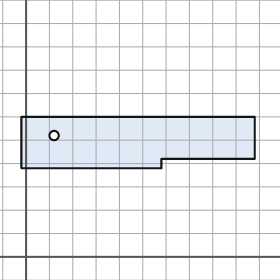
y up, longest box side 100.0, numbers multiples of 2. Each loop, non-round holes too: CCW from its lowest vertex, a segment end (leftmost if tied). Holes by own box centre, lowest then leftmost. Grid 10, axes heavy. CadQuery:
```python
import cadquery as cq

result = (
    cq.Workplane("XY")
    .moveTo(-2.0, 38.0)
    .lineTo(58.0, 38.0)
    .lineTo(58.0, 42.0)
    .lineTo(98.0, 42.0)
    .lineTo(98.0, 60.0)
    .lineTo(-2.0, 60.0)
    .close()
    .moveTo(12.0, 52.0)
    .circle(2.0)
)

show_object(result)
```